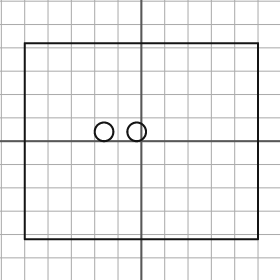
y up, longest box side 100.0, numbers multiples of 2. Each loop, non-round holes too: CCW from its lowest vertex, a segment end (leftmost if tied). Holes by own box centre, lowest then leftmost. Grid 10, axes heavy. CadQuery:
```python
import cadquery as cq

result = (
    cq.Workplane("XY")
    .moveTo(-50.0, -42.0)
    .lineTo(50.0, -42.0)
    .lineTo(50.0, 42.0)
    .lineTo(-50.0, 42.0)
    .close()
    .moveTo(-16.0, 4.0)
    .circle(4.0)
    .moveTo(-2.0, 4.0)
    .circle(4.0)
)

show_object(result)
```